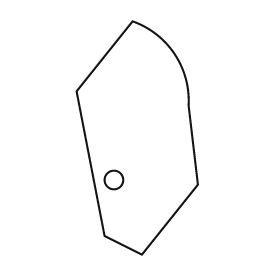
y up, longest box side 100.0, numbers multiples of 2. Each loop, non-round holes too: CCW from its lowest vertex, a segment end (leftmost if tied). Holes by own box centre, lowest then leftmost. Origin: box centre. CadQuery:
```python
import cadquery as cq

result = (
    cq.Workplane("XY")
    .moveTo(2.0, -50.0)
    .lineTo(26.0, -20.0)
    .lineTo(22.0, 14.0)
    .threePointArc((16.0, 36.0), (-2.0, 50.0))
    .lineTo(-26.0, 20.0)
    .lineTo(-14.0, -42.0)
    .close()
    .moveTo(-10.0, -18.0)
    .circle(4.0)
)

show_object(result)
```